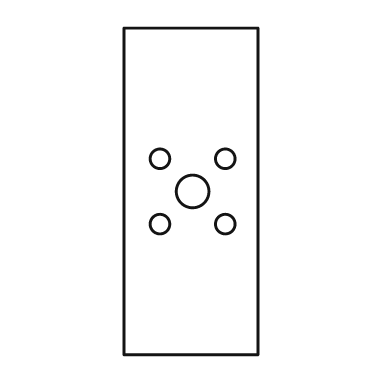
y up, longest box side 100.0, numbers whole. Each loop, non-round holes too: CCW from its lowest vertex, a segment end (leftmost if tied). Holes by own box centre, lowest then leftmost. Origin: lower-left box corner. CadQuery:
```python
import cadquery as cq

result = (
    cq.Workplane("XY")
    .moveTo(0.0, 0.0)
    .lineTo(41.0, 0.0)
    .lineTo(41.0, 100.0)
    .lineTo(0.0, 100.0)
    .close()
    .moveTo(11.0, 40.0)
    .circle(3.0)
    .moveTo(31.0, 40.0)
    .circle(3.0)
    .moveTo(21.0, 50.0)
    .circle(5.0)
    .moveTo(11.0, 60.0)
    .circle(3.0)
    .moveTo(31.0, 60.0)
    .circle(3.0)
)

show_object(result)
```